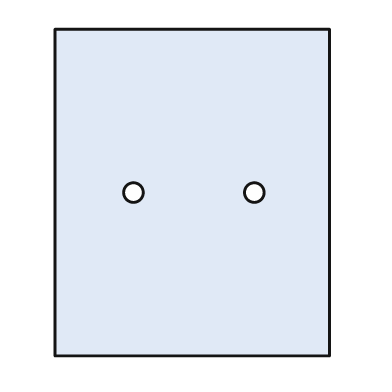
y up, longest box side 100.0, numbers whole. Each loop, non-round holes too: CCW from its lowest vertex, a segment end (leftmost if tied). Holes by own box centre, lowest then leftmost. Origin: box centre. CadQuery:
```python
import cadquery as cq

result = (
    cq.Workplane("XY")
    .moveTo(-42.0, -50.0)
    .lineTo(42.0, -50.0)
    .lineTo(42.0, 50.0)
    .lineTo(-42.0, 50.0)
    .close()
    .moveTo(-18.0, 0.0)
    .circle(3.0)
    .moveTo(19.0, 0.0)
    .circle(3.0)
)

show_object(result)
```